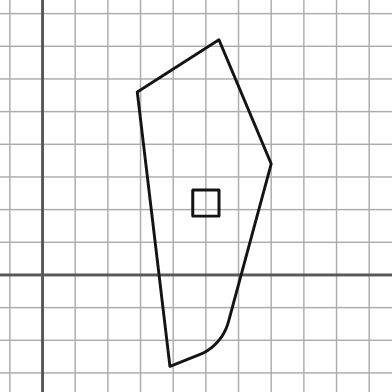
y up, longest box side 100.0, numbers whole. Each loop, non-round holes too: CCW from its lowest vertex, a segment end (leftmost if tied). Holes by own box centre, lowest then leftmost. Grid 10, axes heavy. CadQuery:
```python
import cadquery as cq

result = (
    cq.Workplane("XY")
    .moveTo(39.0, -28.0)
    .lineTo(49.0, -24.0)
    .threePointArc((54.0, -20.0), (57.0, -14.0))
    .lineTo(70.0, 34.0)
    .lineTo(54.0, 72.0)
    .lineTo(29.0, 56.0)
    .close()
    .moveTo(46.0, 18.0)
    .lineTo(54.0, 18.0)
    .lineTo(54.0, 26.0)
    .lineTo(46.0, 26.0)
    .close()
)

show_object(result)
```